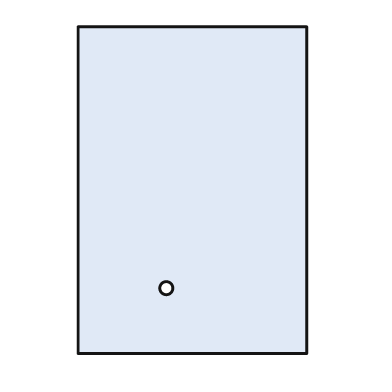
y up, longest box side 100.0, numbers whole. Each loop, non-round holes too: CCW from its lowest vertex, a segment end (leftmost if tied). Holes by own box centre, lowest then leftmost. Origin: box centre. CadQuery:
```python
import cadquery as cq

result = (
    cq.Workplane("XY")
    .moveTo(-35.0, -50.0)
    .lineTo(35.0, -50.0)
    .lineTo(35.0, 50.0)
    .lineTo(-35.0, 50.0)
    .close()
    .moveTo(-8.0, -30.0)
    .circle(2.0)
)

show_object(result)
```